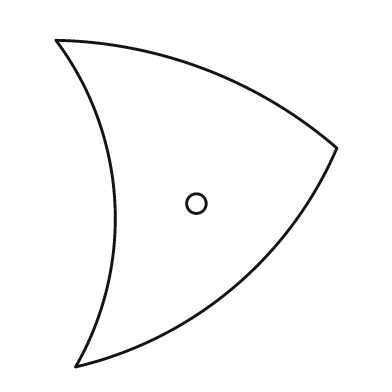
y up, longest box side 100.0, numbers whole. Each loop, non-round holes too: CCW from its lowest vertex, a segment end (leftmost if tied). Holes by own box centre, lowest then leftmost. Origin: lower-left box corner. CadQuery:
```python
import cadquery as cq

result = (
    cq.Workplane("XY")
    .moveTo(6.0, 0.0)
    .threePointArc((54.0, 24.0), (86.0, 67.0))
    .threePointArc((46.0, 91.0), (0.0, 100.0))
    .threePointArc((18.0, 51.0), (6.0, 0.0))
    .close()
    .moveTo(43.0, 50.0)
    .circle(3.0)
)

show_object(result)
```